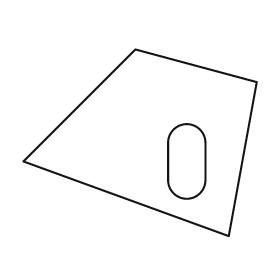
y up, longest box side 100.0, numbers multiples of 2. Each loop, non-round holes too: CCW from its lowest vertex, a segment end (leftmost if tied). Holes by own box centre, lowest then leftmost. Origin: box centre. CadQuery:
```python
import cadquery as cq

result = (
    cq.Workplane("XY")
    .moveTo(38.0, -40.0)
    .lineTo(50.0, 26.0)
    .lineTo(-2.0, 40.0)
    .lineTo(-50.0, -8.0)
    .close()
    .moveTo(12.0, -16.0)
    .threePointArc((20.0, -24.0), (28.0, -16.0))
    .lineTo(28.0, 0.0)
    .threePointArc((20.0, 8.0), (12.0, 0.0))
    .close()
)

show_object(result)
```